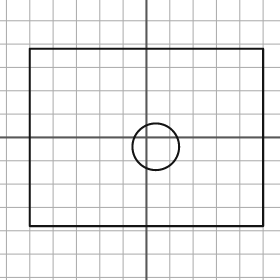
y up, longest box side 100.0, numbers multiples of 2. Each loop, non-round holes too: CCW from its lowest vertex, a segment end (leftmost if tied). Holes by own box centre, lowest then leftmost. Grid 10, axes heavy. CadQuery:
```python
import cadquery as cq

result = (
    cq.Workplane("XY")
    .moveTo(-50.0, -38.0)
    .lineTo(50.0, -38.0)
    .lineTo(50.0, 38.0)
    .lineTo(-50.0, 38.0)
    .close()
    .moveTo(4.0, -4.0)
    .circle(10.0)
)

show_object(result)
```